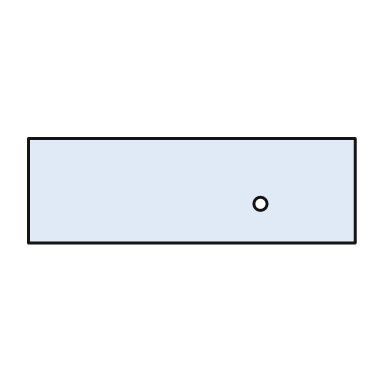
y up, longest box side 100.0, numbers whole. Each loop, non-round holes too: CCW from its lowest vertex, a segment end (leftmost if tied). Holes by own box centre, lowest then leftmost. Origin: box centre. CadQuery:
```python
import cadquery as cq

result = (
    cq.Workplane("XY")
    .moveTo(-50.0, -16.0)
    .lineTo(50.0, -16.0)
    .lineTo(50.0, 16.0)
    .lineTo(-50.0, 16.0)
    .close()
    .moveTo(21.0, -4.0)
    .circle(2.0)
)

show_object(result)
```